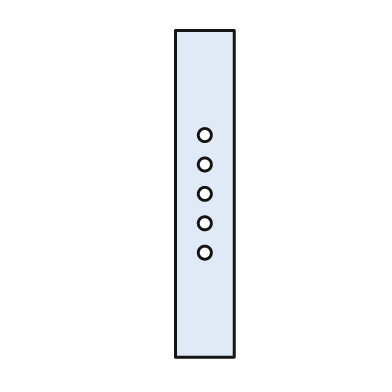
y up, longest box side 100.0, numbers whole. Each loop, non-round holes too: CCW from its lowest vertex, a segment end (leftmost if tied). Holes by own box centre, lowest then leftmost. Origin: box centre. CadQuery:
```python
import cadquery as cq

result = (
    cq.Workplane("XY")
    .moveTo(-9.0, -50.0)
    .lineTo(9.0, -50.0)
    .lineTo(9.0, 50.0)
    .lineTo(-9.0, 50.0)
    .close()
    .moveTo(0.0, -18.0)
    .circle(2.0)
    .moveTo(0.0, -9.0)
    .circle(2.0)
    .moveTo(0.0, 0.0)
    .circle(2.0)
    .moveTo(0.0, 9.0)
    .circle(2.0)
    .moveTo(0.0, 18.0)
    .circle(2.0)
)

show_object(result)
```